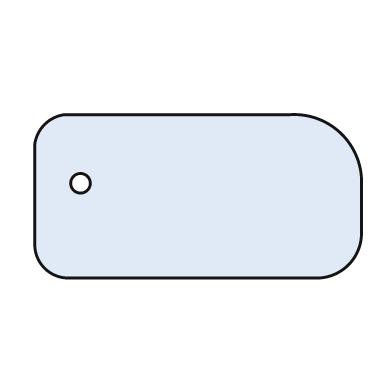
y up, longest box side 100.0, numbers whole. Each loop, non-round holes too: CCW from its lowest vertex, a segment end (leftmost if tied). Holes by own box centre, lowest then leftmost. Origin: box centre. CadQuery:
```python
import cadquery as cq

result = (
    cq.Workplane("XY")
    .moveTo(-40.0, -25.0)
    .lineTo(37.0, -25.0)
    .threePointArc((46.0, -21.0), (50.0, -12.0))
    .lineTo(50.0, 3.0)
    .threePointArc((44.0, 19.0), (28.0, 25.0))
    .lineTo(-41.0, 25.0)
    .threePointArc((-47.0, 22.0), (-50.0, 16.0))
    .lineTo(-50.0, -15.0)
    .threePointArc((-47.0, -22.0), (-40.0, -25.0))
    .close()
    .moveTo(-36.0, 4.0)
    .circle(3.0)
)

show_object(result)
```